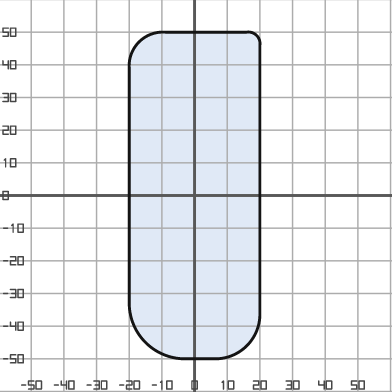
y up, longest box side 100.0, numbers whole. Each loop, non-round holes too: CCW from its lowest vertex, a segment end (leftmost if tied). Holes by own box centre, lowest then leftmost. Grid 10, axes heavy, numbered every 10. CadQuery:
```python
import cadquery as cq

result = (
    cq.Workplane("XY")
    .moveTo(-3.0, -50.0)
    .lineTo(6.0, -50.0)
    .threePointArc((16.0, -46.0), (20.0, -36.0))
    .lineTo(20.0, 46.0)
    .threePointArc((19.0, 49.0), (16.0, 50.0))
    .lineTo(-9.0, 50.0)
    .threePointArc((-17.0, 47.0), (-20.0, 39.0))
    .lineTo(-20.0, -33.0)
    .threePointArc((-15.0, -45.0), (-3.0, -50.0))
    .close()
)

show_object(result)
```